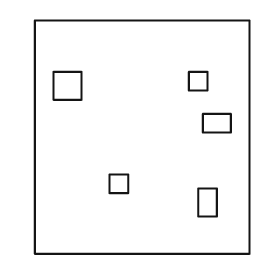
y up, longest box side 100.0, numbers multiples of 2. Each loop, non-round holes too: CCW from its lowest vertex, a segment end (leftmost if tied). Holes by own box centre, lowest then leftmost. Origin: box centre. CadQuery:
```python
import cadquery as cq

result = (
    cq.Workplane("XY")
    .moveTo(-46.0, -50.0)
    .lineTo(46.0, -50.0)
    .lineTo(46.0, 50.0)
    .lineTo(-46.0, 50.0)
    .close()
    .moveTo(24.0, -34.0)
    .lineTo(32.0, -34.0)
    .lineTo(32.0, -22.0)
    .lineTo(24.0, -22.0)
    .close()
    .moveTo(-14.0, -24.0)
    .lineTo(-6.0, -24.0)
    .lineTo(-6.0, -16.0)
    .lineTo(-14.0, -16.0)
    .close()
    .moveTo(26.0, 2.0)
    .lineTo(38.0, 2.0)
    .lineTo(38.0, 10.0)
    .lineTo(26.0, 10.0)
    .close()
    .moveTo(-38.0, 16.0)
    .lineTo(-26.0, 16.0)
    .lineTo(-26.0, 28.0)
    .lineTo(-38.0, 28.0)
    .close()
    .moveTo(20.0, 20.0)
    .lineTo(28.0, 20.0)
    .lineTo(28.0, 28.0)
    .lineTo(20.0, 28.0)
    .close()
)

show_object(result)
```